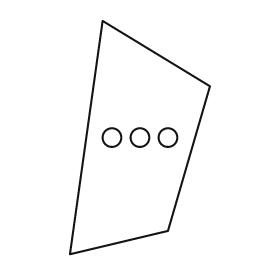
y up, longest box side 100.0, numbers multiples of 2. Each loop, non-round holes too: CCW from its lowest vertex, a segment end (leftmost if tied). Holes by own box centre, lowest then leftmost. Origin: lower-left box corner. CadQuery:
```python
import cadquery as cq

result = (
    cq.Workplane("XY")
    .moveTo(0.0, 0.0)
    .lineTo(42.0, 10.0)
    .lineTo(60.0, 72.0)
    .lineTo(14.0, 100.0)
    .close()
    .moveTo(18.0, 50.0)
    .circle(4.0)
    .moveTo(30.0, 50.0)
    .circle(4.0)
    .moveTo(42.0, 50.0)
    .circle(4.0)
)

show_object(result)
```